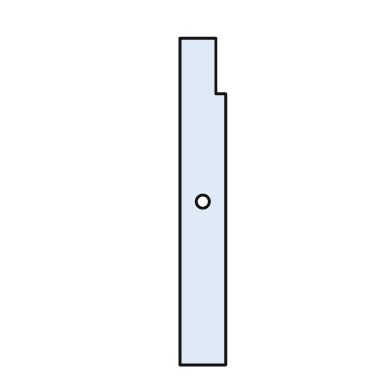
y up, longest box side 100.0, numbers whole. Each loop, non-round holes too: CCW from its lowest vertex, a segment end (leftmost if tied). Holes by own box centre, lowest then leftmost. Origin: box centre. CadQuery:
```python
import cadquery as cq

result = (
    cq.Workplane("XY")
    .moveTo(-7.0, -50.0)
    .lineTo(7.0, -50.0)
    .lineTo(7.0, 33.0)
    .lineTo(4.0, 33.0)
    .lineTo(4.0, 50.0)
    .lineTo(-7.0, 50.0)
    .close()
    .moveTo(0.0, 0.0)
    .circle(2.0)
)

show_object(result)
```